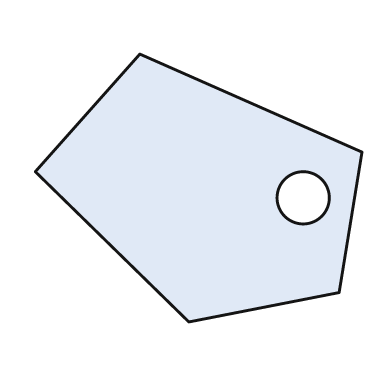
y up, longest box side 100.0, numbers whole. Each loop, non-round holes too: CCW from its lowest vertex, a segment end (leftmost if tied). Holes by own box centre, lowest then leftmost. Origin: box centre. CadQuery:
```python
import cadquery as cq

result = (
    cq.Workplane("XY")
    .moveTo(-3.0, -41.0)
    .lineTo(43.0, -32.0)
    .lineTo(50.0, 11.0)
    .lineTo(-18.0, 41.0)
    .lineTo(-50.0, 5.0)
    .close()
    .moveTo(32.0, -3.0)
    .circle(8.0)
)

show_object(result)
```